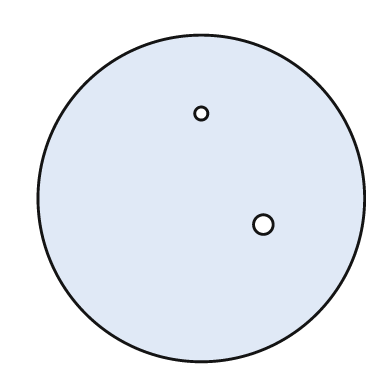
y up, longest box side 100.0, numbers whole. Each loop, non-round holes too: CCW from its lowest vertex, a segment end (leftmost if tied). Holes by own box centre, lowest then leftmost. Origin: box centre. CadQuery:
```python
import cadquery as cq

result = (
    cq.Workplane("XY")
    .moveTo(0.0, 0.0)
    .circle(50.0)
    .moveTo(19.0, -8.0)
    .circle(3.0)
    .moveTo(0.0, 26.0)
    .circle(2.0)
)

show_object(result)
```